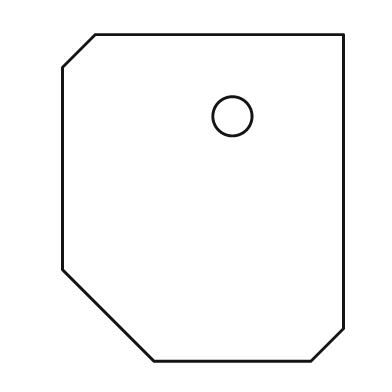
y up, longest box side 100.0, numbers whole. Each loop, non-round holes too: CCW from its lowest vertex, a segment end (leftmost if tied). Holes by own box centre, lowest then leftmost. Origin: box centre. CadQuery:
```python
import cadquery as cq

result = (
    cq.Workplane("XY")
    .moveTo(-15.0, -50.0)
    .lineTo(33.0, -50.0)
    .lineTo(43.0, -40.0)
    .lineTo(43.0, 50.0)
    .lineTo(-33.0, 50.0)
    .lineTo(-43.0, 40.0)
    .lineTo(-43.0, -22.0)
    .close()
    .moveTo(9.0, 25.0)
    .circle(6.0)
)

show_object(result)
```